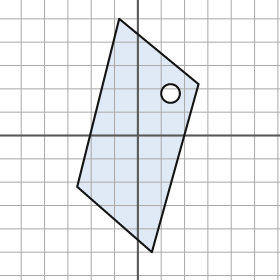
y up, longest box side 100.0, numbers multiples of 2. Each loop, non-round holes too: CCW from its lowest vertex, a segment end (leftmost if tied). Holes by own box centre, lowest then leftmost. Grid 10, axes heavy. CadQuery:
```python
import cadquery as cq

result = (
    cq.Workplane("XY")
    .moveTo(6.0, -50.0)
    .lineTo(26.0, 22.0)
    .lineTo(-8.0, 50.0)
    .lineTo(-26.0, -22.0)
    .close()
    .moveTo(14.0, 18.0)
    .circle(4.0)
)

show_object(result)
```